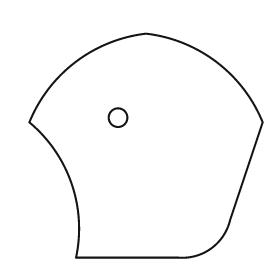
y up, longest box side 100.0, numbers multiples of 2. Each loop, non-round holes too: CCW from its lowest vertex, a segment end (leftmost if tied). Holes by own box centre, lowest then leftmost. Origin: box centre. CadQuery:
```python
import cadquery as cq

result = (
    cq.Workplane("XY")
    .moveTo(-30.0, -48.0)
    .lineTo(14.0, -48.0)
    .threePointArc((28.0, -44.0), (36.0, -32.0))
    .lineTo(50.0, 10.0)
    .threePointArc((30.0, 36.0), (0.0, 48.0))
    .threePointArc((-30.0, 36.0), (-50.0, 10.0))
    .threePointArc((-32.0, -16.0), (-30.0, -48.0))
    .close()
    .moveTo(-12.0, 12.0)
    .circle(4.0)
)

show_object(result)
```